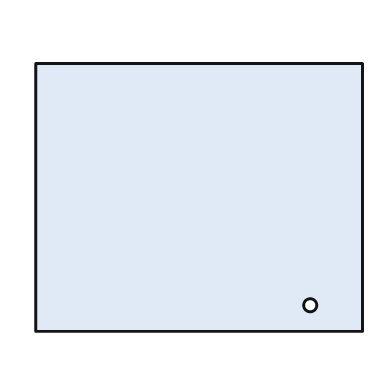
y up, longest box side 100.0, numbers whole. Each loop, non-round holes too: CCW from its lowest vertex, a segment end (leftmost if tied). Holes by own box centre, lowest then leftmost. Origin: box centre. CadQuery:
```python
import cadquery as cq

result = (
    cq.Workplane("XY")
    .moveTo(-50.0, -41.0)
    .lineTo(50.0, -41.0)
    .lineTo(50.0, 41.0)
    .lineTo(-50.0, 41.0)
    .close()
    .moveTo(34.0, -33.0)
    .circle(2.0)
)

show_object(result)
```